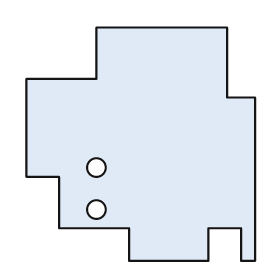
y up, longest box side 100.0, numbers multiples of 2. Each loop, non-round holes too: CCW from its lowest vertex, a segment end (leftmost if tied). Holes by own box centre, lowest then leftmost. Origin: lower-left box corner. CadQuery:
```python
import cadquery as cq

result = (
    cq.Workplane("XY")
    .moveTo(44.0, 0.0)
    .lineTo(78.0, 0.0)
    .lineTo(78.0, 14.0)
    .lineTo(92.0, 14.0)
    .lineTo(92.0, 0.0)
    .lineTo(98.0, 0.0)
    .lineTo(98.0, 70.0)
    .lineTo(86.0, 70.0)
    .lineTo(86.0, 100.0)
    .lineTo(30.0, 100.0)
    .lineTo(30.0, 78.0)
    .lineTo(0.0, 78.0)
    .lineTo(0.0, 36.0)
    .lineTo(14.0, 36.0)
    .lineTo(14.0, 14.0)
    .lineTo(44.0, 14.0)
    .close()
    .moveTo(30.0, 22.0)
    .circle(4.0)
    .moveTo(30.0, 40.0)
    .circle(4.0)
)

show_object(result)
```